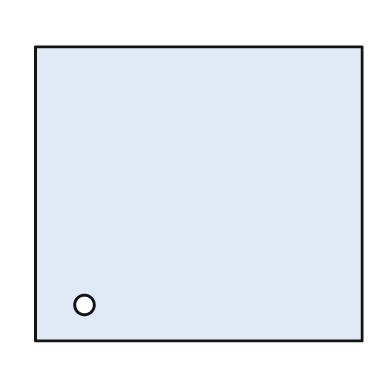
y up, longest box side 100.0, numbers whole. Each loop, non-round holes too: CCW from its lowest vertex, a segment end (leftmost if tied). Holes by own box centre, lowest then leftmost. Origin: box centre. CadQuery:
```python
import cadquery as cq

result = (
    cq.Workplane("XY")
    .moveTo(-50.0, -45.0)
    .lineTo(50.0, -45.0)
    .lineTo(50.0, 45.0)
    .lineTo(-50.0, 45.0)
    .close()
    .moveTo(-35.0, -34.0)
    .circle(3.0)
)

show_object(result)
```